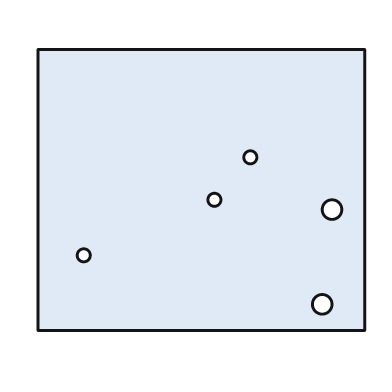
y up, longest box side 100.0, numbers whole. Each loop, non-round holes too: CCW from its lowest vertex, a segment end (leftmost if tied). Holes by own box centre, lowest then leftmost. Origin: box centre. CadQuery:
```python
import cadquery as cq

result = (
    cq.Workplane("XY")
    .moveTo(-50.0, -43.0)
    .lineTo(50.0, -43.0)
    .lineTo(50.0, 43.0)
    .lineTo(-50.0, 43.0)
    .close()
    .moveTo(37.0, -35.0)
    .circle(3.0)
    .moveTo(-36.0, -20.0)
    .circle(2.0)
    .moveTo(40.0, -6.0)
    .circle(3.0)
    .moveTo(4.0, -3.0)
    .circle(2.0)
    .moveTo(15.0, 10.0)
    .circle(2.0)
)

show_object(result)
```